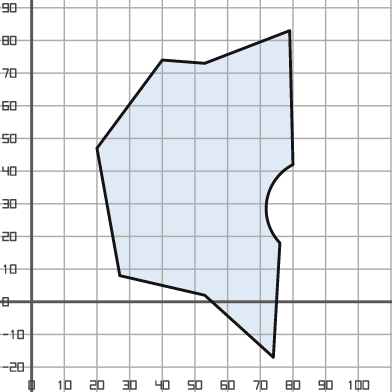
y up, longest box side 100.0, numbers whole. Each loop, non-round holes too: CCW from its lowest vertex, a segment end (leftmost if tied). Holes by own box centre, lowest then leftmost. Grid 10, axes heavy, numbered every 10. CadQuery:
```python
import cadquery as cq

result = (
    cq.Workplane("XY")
    .moveTo(74.0, -17.0)
    .lineTo(76.0, 18.0)
    .threePointArc((72.0, 31.0), (80.0, 42.0))
    .lineTo(79.0, 83.0)
    .lineTo(53.0, 73.0)
    .lineTo(40.0, 74.0)
    .lineTo(20.0, 47.0)
    .lineTo(27.0, 8.0)
    .lineTo(53.0, 2.0)
    .close()
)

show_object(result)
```